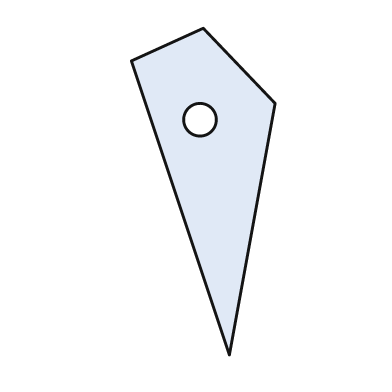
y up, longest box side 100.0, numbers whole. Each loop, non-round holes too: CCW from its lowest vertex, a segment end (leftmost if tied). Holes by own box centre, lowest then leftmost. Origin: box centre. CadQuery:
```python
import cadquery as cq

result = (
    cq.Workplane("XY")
    .moveTo(8.0, -50.0)
    .lineTo(22.0, 27.0)
    .lineTo(0.0, 50.0)
    .lineTo(-22.0, 40.0)
    .close()
    .moveTo(-1.0, 22.0)
    .circle(5.0)
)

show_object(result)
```